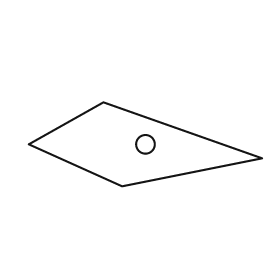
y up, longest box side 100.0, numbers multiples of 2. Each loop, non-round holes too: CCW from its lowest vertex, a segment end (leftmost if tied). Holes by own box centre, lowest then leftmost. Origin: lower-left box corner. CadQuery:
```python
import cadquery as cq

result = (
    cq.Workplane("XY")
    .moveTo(40.0, 0.0)
    .lineTo(100.0, 12.0)
    .lineTo(32.0, 36.0)
    .lineTo(0.0, 18.0)
    .close()
    .moveTo(50.0, 18.0)
    .circle(4.0)
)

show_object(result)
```